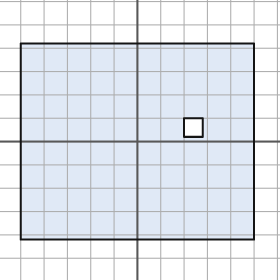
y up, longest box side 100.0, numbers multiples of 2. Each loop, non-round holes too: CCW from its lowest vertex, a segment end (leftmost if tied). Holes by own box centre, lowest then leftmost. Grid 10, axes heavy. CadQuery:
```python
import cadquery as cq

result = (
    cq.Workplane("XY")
    .moveTo(-50.0, -42.0)
    .lineTo(50.0, -42.0)
    .lineTo(50.0, 42.0)
    .lineTo(-50.0, 42.0)
    .close()
    .moveTo(20.0, 2.0)
    .lineTo(28.0, 2.0)
    .lineTo(28.0, 10.0)
    .lineTo(20.0, 10.0)
    .close()
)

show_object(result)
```